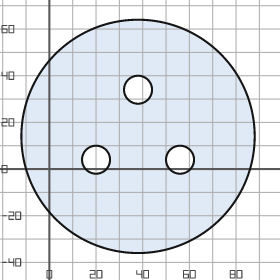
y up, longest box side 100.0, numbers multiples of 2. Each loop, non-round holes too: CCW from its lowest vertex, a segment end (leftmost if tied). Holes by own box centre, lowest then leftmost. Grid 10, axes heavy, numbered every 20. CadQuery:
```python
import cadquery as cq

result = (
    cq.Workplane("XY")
    .moveTo(38.0, 14.0)
    .circle(50.0)
    .moveTo(20.0, 4.0)
    .circle(6.0)
    .moveTo(56.0, 4.0)
    .circle(6.0)
    .moveTo(38.0, 34.0)
    .circle(6.0)
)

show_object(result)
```